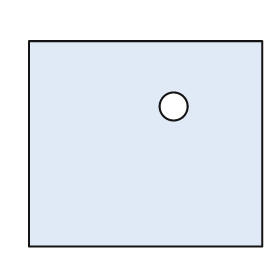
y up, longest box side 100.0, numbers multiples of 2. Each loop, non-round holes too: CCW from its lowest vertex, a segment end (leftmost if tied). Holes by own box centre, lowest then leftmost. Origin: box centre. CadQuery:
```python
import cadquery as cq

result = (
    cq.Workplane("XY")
    .moveTo(-50.0, -44.0)
    .lineTo(50.0, -44.0)
    .lineTo(50.0, 44.0)
    .lineTo(-50.0, 44.0)
    .close()
    .moveTo(12.0, 16.0)
    .circle(6.0)
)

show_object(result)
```